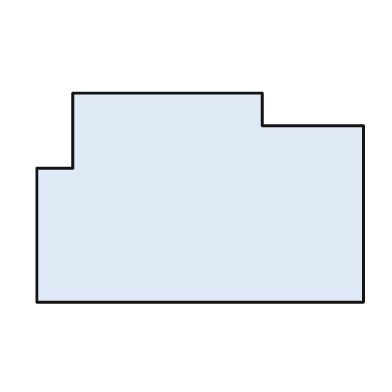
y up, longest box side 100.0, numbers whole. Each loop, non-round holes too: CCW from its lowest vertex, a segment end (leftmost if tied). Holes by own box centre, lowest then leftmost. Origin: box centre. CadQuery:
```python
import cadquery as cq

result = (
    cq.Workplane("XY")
    .moveTo(-50.0, -32.0)
    .lineTo(50.0, -32.0)
    .lineTo(50.0, 22.0)
    .lineTo(19.0, 22.0)
    .lineTo(19.0, 32.0)
    .lineTo(-39.0, 32.0)
    .lineTo(-39.0, 9.0)
    .lineTo(-50.0, 9.0)
    .close()
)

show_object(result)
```